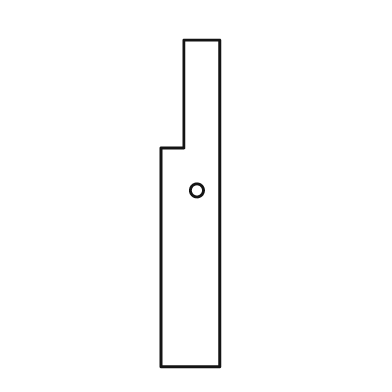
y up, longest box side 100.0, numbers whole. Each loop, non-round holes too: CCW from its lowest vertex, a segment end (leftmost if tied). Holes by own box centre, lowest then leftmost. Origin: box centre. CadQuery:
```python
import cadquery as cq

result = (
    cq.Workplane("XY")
    .moveTo(-9.0, -50.0)
    .lineTo(9.0, -50.0)
    .lineTo(9.0, 50.0)
    .lineTo(-2.0, 50.0)
    .lineTo(-2.0, 17.0)
    .lineTo(-9.0, 17.0)
    .close()
    .moveTo(2.0, 4.0)
    .circle(2.0)
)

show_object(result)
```